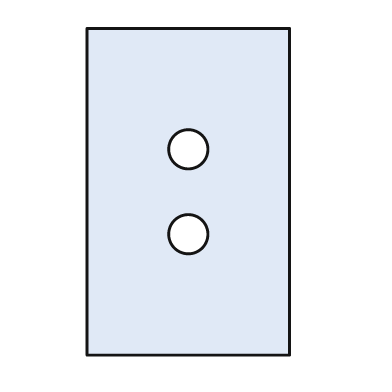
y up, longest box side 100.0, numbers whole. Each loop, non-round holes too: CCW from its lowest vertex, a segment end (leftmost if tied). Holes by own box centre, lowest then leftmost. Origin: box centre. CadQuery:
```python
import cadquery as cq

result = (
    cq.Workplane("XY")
    .moveTo(-31.0, -50.0)
    .lineTo(31.0, -50.0)
    .lineTo(31.0, 50.0)
    .lineTo(-31.0, 50.0)
    .close()
    .moveTo(0.0, -13.0)
    .circle(6.0)
    .moveTo(0.0, 13.0)
    .circle(6.0)
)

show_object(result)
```